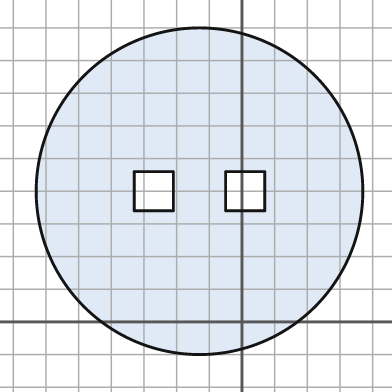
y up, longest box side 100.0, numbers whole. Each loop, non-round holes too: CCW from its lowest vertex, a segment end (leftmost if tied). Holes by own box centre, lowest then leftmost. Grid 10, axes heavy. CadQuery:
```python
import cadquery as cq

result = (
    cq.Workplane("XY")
    .moveTo(-13.0, 40.0)
    .circle(50.0)
    .moveTo(-33.0, 34.0)
    .lineTo(-21.0, 34.0)
    .lineTo(-21.0, 46.0)
    .lineTo(-33.0, 46.0)
    .close()
    .moveTo(-5.0, 34.0)
    .lineTo(7.0, 34.0)
    .lineTo(7.0, 46.0)
    .lineTo(-5.0, 46.0)
    .close()
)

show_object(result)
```